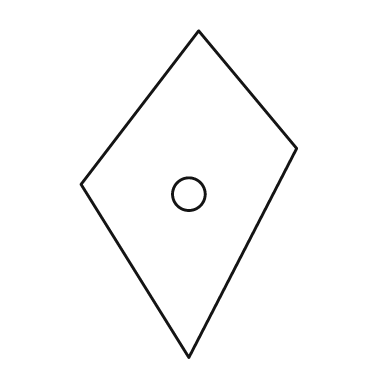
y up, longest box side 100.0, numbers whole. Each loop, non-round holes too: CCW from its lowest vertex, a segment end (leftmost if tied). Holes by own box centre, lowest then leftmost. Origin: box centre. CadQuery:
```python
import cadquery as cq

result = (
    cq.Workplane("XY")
    .moveTo(0.0, -50.0)
    .lineTo(33.0, 14.0)
    .lineTo(3.0, 50.0)
    .lineTo(-33.0, 3.0)
    .close()
    .moveTo(0.0, 0.0)
    .circle(5.0)
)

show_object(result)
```